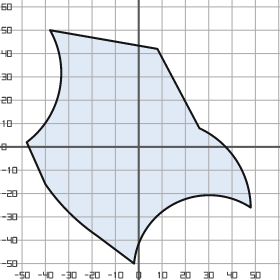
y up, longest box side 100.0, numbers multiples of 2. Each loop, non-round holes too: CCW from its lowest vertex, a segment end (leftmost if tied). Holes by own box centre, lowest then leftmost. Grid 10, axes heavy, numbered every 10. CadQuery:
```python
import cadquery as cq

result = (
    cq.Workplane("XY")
    .moveTo(-2.0, -50.0)
    .threePointArc((16.0, -24.0), (48.0, -26.0))
    .threePointArc((42.0, -6.0), (26.0, 8.0))
    .lineTo(8.0, 42.0)
    .lineTo(-38.0, 50.0)
    .threePointArc((-34.0, 24.0), (-48.0, 2.0))
    .lineTo(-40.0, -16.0)
    .threePointArc((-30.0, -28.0), (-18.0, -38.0))
    .close()
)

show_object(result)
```